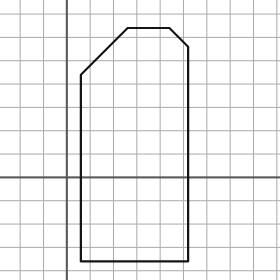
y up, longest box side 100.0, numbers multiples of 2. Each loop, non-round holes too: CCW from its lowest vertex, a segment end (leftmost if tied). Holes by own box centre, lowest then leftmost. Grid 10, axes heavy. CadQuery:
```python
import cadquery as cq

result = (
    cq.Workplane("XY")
    .moveTo(6.0, -36.0)
    .lineTo(52.0, -36.0)
    .lineTo(52.0, 56.0)
    .lineTo(44.0, 64.0)
    .lineTo(26.0, 64.0)
    .lineTo(6.0, 44.0)
    .close()
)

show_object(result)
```